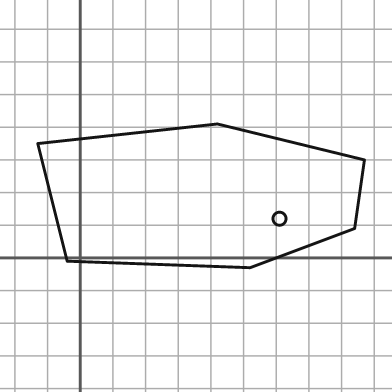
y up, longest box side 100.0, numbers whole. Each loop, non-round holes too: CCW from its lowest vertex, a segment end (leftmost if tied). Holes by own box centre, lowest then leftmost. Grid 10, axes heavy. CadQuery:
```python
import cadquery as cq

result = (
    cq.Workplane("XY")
    .moveTo(52.0, -3.0)
    .lineTo(84.0, 9.0)
    .lineTo(87.0, 30.0)
    .lineTo(42.0, 41.0)
    .lineTo(-13.0, 35.0)
    .lineTo(-4.0, -1.0)
    .close()
    .moveTo(61.0, 12.0)
    .circle(2.0)
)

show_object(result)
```